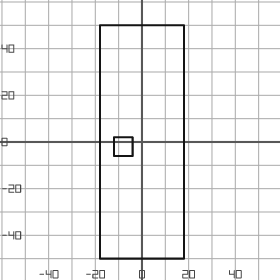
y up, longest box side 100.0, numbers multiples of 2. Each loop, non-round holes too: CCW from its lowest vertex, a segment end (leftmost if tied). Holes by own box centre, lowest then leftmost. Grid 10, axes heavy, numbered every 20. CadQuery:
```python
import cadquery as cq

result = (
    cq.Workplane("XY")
    .moveTo(-18.0, -50.0)
    .lineTo(18.0, -50.0)
    .lineTo(18.0, 50.0)
    .lineTo(-18.0, 50.0)
    .close()
    .moveTo(-12.0, -6.0)
    .lineTo(-4.0, -6.0)
    .lineTo(-4.0, 2.0)
    .lineTo(-12.0, 2.0)
    .close()
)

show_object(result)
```